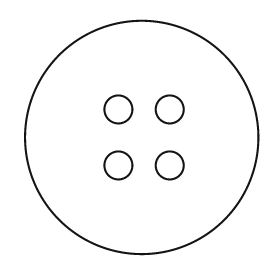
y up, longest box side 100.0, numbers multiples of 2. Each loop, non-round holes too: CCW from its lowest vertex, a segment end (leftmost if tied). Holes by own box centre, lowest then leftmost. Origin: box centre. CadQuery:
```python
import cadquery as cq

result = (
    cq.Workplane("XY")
    .moveTo(0.0, 0.0)
    .circle(50.0)
    .moveTo(-10.0, -12.0)
    .circle(6.0)
    .moveTo(12.0, -12.0)
    .circle(6.0)
    .moveTo(-10.0, 12.0)
    .circle(6.0)
    .moveTo(12.0, 12.0)
    .circle(6.0)
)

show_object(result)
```